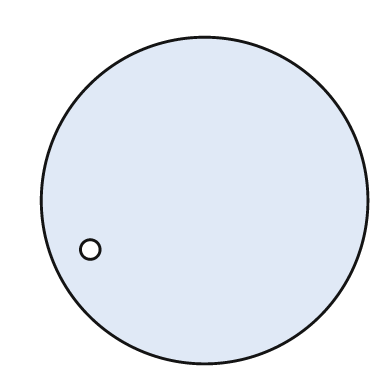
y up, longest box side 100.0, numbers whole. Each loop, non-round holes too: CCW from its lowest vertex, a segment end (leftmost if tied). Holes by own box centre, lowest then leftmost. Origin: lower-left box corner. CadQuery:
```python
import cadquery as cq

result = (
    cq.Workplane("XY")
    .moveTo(50.0, 50.0)
    .circle(50.0)
    .moveTo(15.0, 35.0)
    .circle(3.0)
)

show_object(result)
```